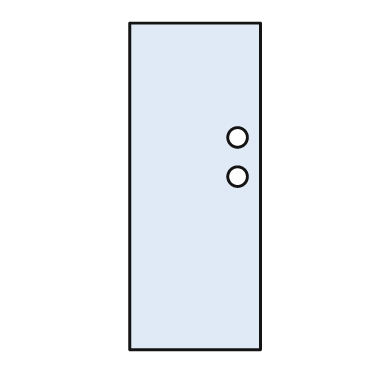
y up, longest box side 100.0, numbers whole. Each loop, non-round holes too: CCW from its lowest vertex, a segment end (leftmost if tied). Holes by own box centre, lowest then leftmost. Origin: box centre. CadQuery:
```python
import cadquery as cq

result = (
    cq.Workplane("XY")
    .moveTo(-20.0, -50.0)
    .lineTo(20.0, -50.0)
    .lineTo(20.0, 50.0)
    .lineTo(-20.0, 50.0)
    .close()
    .moveTo(13.0, 3.0)
    .circle(3.0)
    .moveTo(13.0, 15.0)
    .circle(3.0)
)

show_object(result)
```